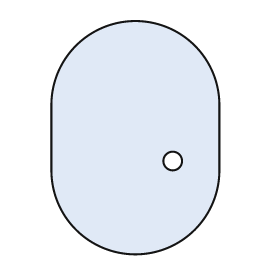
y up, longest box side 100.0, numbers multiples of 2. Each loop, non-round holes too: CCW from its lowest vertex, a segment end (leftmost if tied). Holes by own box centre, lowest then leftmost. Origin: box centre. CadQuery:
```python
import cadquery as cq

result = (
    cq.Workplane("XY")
    .moveTo(-36.0, -14.0)
    .threePointArc((0.0, -50.0), (36.0, -14.0))
    .lineTo(36.0, 14.0)
    .threePointArc((0.0, 50.0), (-36.0, 14.0))
    .close()
    .moveTo(16.0, -10.0)
    .circle(4.0)
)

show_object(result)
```